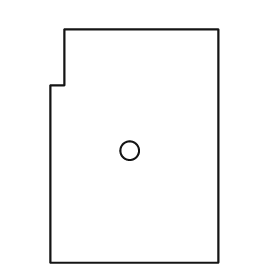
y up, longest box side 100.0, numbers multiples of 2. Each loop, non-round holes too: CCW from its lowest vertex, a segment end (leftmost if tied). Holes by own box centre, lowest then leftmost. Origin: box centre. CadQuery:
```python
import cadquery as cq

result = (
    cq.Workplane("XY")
    .moveTo(-36.0, -50.0)
    .lineTo(36.0, -50.0)
    .lineTo(36.0, 50.0)
    .lineTo(-30.0, 50.0)
    .lineTo(-30.0, 26.0)
    .lineTo(-36.0, 26.0)
    .close()
    .moveTo(-2.0, -2.0)
    .circle(4.0)
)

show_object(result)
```